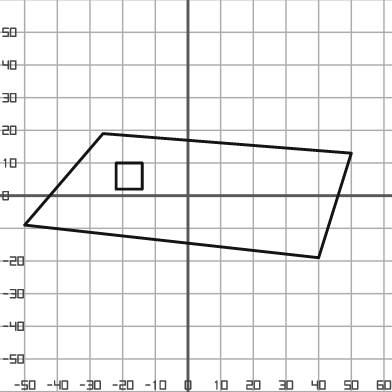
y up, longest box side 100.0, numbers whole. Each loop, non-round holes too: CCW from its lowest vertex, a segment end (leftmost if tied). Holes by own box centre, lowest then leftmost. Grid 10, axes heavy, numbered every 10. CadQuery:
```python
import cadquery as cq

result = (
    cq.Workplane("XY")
    .moveTo(40.0, -19.0)
    .lineTo(50.0, 13.0)
    .lineTo(-26.0, 19.0)
    .lineTo(-50.0, -9.0)
    .close()
    .moveTo(-22.0, 2.0)
    .lineTo(-14.0, 2.0)
    .lineTo(-14.0, 10.0)
    .lineTo(-22.0, 10.0)
    .close()
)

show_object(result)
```